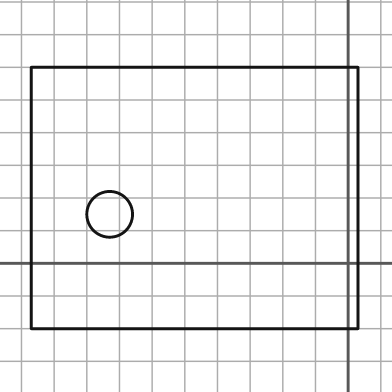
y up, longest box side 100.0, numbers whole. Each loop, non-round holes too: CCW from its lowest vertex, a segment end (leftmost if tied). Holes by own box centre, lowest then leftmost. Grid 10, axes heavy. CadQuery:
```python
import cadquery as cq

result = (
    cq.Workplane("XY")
    .moveTo(-97.0, -20.0)
    .lineTo(3.0, -20.0)
    .lineTo(3.0, 60.0)
    .lineTo(-97.0, 60.0)
    .close()
    .moveTo(-73.0, 15.0)
    .circle(7.0)
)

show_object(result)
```